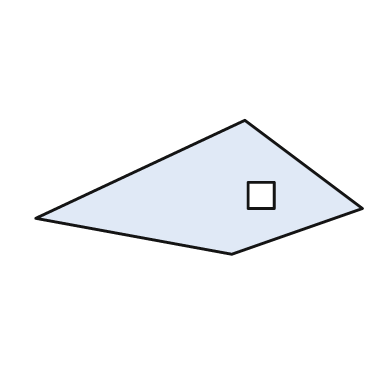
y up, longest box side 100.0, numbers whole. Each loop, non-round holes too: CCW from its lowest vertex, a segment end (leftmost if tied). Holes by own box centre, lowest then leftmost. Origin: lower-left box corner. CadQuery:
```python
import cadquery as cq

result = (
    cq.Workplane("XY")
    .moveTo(60.0, 0.0)
    .lineTo(100.0, 14.0)
    .lineTo(64.0, 41.0)
    .lineTo(0.0, 11.0)
    .close()
    .moveTo(65.0, 14.0)
    .lineTo(73.0, 14.0)
    .lineTo(73.0, 22.0)
    .lineTo(65.0, 22.0)
    .close()
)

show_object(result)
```